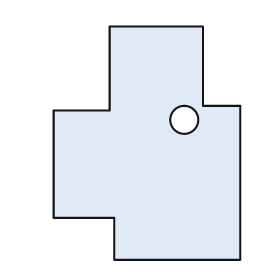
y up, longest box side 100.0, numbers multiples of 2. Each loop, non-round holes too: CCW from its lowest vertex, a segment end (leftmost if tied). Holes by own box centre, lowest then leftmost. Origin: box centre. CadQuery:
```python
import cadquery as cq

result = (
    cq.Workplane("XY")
    .moveTo(-14.0, -50.0)
    .lineTo(40.0, -50.0)
    .lineTo(40.0, 16.0)
    .lineTo(24.0, 16.0)
    .lineTo(24.0, 50.0)
    .lineTo(-16.0, 50.0)
    .lineTo(-16.0, 14.0)
    .lineTo(-40.0, 14.0)
    .lineTo(-40.0, -32.0)
    .lineTo(-14.0, -32.0)
    .close()
    .moveTo(16.0, 10.0)
    .circle(6.0)
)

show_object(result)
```